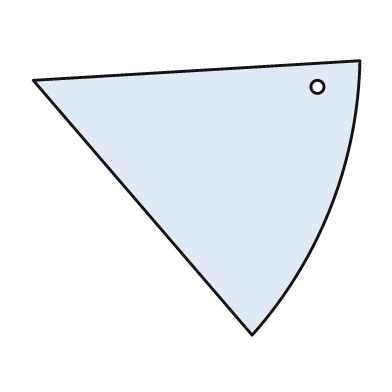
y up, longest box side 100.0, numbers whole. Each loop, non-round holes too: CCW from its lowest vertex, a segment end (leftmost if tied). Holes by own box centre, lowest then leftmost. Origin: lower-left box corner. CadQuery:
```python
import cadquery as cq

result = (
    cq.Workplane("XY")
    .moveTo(67.0, 0.0)
    .threePointArc((91.0, 39.0), (100.0, 84.0))
    .lineTo(0.0, 78.0)
    .close()
    .moveTo(87.0, 76.0)
    .circle(2.0)
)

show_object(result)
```